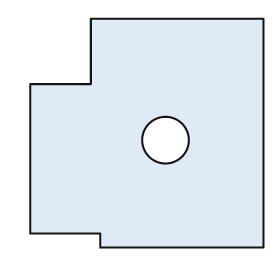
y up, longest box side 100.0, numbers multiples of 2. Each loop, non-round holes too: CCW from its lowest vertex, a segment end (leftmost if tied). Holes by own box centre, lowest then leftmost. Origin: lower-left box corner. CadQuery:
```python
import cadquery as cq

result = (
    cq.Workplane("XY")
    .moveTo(30.0, 0.0)
    .lineTo(100.0, 0.0)
    .lineTo(100.0, 98.0)
    .lineTo(26.0, 98.0)
    .lineTo(26.0, 70.0)
    .lineTo(0.0, 70.0)
    .lineTo(0.0, 6.0)
    .lineTo(30.0, 6.0)
    .close()
    .moveTo(58.0, 46.0)
    .circle(10.0)
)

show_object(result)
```